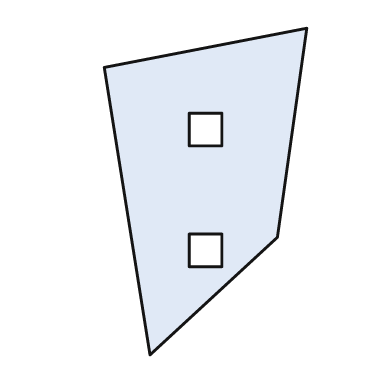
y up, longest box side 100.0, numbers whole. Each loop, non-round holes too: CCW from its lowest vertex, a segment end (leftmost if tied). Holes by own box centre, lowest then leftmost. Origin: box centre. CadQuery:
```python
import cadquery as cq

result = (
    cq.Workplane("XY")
    .moveTo(-17.0, -50.0)
    .lineTo(22.0, -14.0)
    .lineTo(31.0, 50.0)
    .lineTo(-31.0, 38.0)
    .close()
    .moveTo(-5.0, -23.0)
    .lineTo(5.0, -23.0)
    .lineTo(5.0, -13.0)
    .lineTo(-5.0, -13.0)
    .close()
    .moveTo(-5.0, 14.0)
    .lineTo(5.0, 14.0)
    .lineTo(5.0, 24.0)
    .lineTo(-5.0, 24.0)
    .close()
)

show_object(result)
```